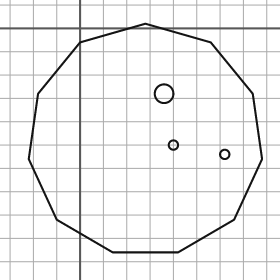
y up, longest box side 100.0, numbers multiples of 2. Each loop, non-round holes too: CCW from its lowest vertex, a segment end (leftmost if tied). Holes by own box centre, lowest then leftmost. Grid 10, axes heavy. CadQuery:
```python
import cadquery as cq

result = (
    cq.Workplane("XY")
    .moveTo(14.0, -96.0)
    .lineTo(42.0, -96.0)
    .lineTo(66.0, -82.0)
    .lineTo(78.0, -56.0)
    .lineTo(74.0, -28.0)
    .lineTo(56.0, -6.0)
    .lineTo(28.0, 2.0)
    .lineTo(0.0, -6.0)
    .lineTo(-18.0, -28.0)
    .lineTo(-22.0, -56.0)
    .lineTo(-10.0, -82.0)
    .close()
    .moveTo(62.0, -54.0)
    .circle(2.0)
    .moveTo(40.0, -50.0)
    .circle(2.0)
    .moveTo(36.0, -28.0)
    .circle(4.0)
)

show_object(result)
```